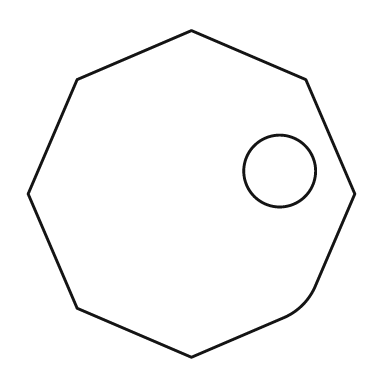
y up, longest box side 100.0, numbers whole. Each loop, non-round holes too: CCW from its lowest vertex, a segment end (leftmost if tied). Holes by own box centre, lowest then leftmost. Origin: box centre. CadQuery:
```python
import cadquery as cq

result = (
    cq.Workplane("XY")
    .moveTo(0.0, -50.0)
    .lineTo(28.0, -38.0)
    .threePointArc((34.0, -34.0), (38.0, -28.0))
    .lineTo(50.0, 0.0)
    .lineTo(35.0, 35.0)
    .lineTo(0.0, 50.0)
    .lineTo(-35.0, 35.0)
    .lineTo(-50.0, 0.0)
    .lineTo(-35.0, -35.0)
    .close()
    .moveTo(27.0, 7.0)
    .circle(11.0)
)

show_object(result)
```